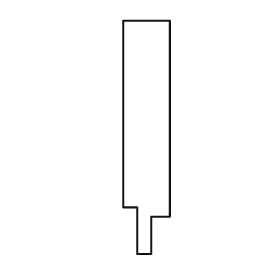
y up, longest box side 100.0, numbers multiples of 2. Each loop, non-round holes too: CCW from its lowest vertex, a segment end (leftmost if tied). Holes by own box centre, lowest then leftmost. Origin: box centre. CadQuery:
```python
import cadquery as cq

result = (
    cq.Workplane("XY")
    .moveTo(-4.0, -50.0)
    .lineTo(2.0, -50.0)
    .lineTo(2.0, -34.0)
    .lineTo(10.0, -34.0)
    .lineTo(10.0, 50.0)
    .lineTo(-10.0, 50.0)
    .lineTo(-10.0, -30.0)
    .lineTo(-4.0, -30.0)
    .close()
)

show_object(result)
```